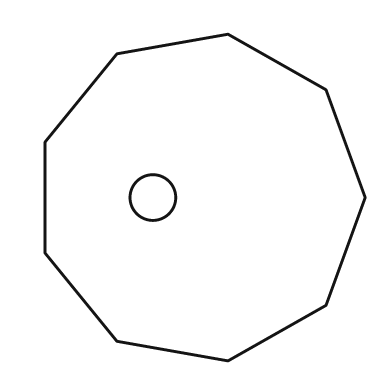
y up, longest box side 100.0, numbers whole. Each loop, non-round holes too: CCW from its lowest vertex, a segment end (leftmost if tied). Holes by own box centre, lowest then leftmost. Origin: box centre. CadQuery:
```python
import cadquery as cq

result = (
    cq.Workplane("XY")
    .moveTo(7.0, -50.0)
    .lineTo(37.0, -33.0)
    .lineTo(49.0, 0.0)
    .lineTo(37.0, 33.0)
    .lineTo(7.0, 50.0)
    .lineTo(-27.0, 44.0)
    .lineTo(-49.0, 17.0)
    .lineTo(-49.0, -17.0)
    .lineTo(-27.0, -44.0)
    .close()
    .moveTo(-16.0, 0.0)
    .circle(7.0)
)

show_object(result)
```